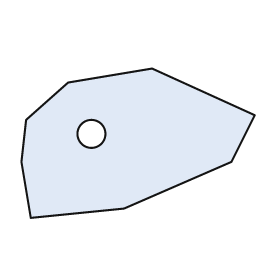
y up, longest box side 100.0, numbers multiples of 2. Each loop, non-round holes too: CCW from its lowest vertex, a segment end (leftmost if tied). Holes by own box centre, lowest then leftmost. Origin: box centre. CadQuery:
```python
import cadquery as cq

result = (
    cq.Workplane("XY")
    .moveTo(-46.0, -32.0)
    .lineTo(-6.0, -28.0)
    .lineTo(40.0, -8.0)
    .lineTo(50.0, 12.0)
    .lineTo(6.0, 32.0)
    .lineTo(-30.0, 26.0)
    .lineTo(-48.0, 10.0)
    .lineTo(-50.0, -8.0)
    .close()
    .moveTo(-20.0, 4.0)
    .circle(6.0)
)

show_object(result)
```